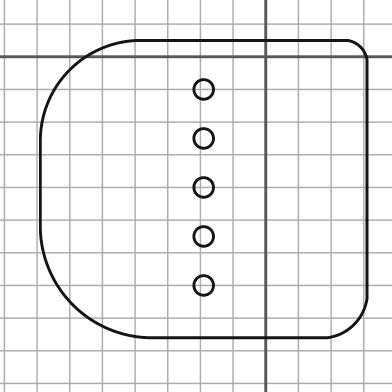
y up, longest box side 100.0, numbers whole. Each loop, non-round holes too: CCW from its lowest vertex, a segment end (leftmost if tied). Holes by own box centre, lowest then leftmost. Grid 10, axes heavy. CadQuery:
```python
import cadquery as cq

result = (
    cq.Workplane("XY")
    .moveTo(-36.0, -86.0)
    .lineTo(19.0, -86.0)
    .threePointArc((27.0, -82.0), (31.0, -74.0))
    .lineTo(31.0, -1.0)
    .threePointArc((29.0, 3.0), (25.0, 5.0))
    .lineTo(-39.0, 5.0)
    .threePointArc((-60.0, -4.0), (-69.0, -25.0))
    .lineTo(-69.0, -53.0)
    .threePointArc((-59.0, -76.0), (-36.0, -86.0))
    .close()
    .moveTo(-19.0, -70.0)
    .circle(3.0)
    .moveTo(-19.0, -55.0)
    .circle(3.0)
    .moveTo(-19.0, -40.0)
    .circle(3.0)
    .moveTo(-19.0, -25.0)
    .circle(3.0)
    .moveTo(-19.0, -10.0)
    .circle(3.0)
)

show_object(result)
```